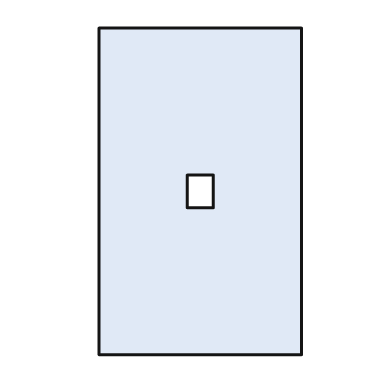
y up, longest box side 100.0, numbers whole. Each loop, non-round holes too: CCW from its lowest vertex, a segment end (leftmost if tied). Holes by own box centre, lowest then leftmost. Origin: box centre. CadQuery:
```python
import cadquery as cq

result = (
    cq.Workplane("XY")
    .moveTo(-31.0, -50.0)
    .lineTo(31.0, -50.0)
    .lineTo(31.0, 50.0)
    .lineTo(-31.0, 50.0)
    .close()
    .moveTo(-4.0, -5.0)
    .lineTo(4.0, -5.0)
    .lineTo(4.0, 5.0)
    .lineTo(-4.0, 5.0)
    .close()
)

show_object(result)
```